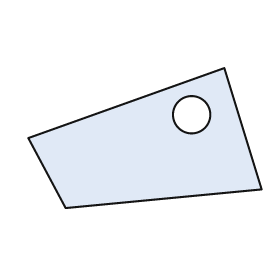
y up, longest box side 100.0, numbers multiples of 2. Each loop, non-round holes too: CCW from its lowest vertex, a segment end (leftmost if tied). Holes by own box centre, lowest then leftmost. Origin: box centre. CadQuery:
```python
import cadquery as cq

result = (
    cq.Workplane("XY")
    .moveTo(-34.0, -30.0)
    .lineTo(50.0, -22.0)
    .lineTo(34.0, 30.0)
    .lineTo(-50.0, 0.0)
    .close()
    .moveTo(20.0, 10.0)
    .circle(8.0)
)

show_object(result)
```